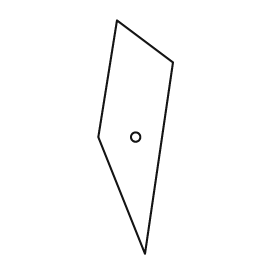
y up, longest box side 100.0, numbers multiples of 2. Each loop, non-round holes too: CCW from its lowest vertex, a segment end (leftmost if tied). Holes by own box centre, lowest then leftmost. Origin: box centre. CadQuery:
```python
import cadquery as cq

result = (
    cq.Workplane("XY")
    .moveTo(4.0, -50.0)
    .lineTo(16.0, 32.0)
    .lineTo(-8.0, 50.0)
    .lineTo(-16.0, 0.0)
    .close()
    .moveTo(0.0, 0.0)
    .circle(2.0)
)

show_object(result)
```